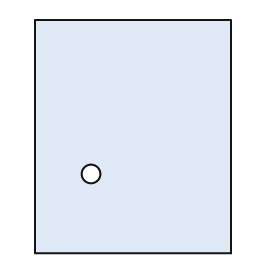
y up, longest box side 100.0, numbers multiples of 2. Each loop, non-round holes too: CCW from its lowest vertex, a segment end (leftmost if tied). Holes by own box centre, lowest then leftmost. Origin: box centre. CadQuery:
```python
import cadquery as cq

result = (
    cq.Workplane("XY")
    .moveTo(-42.0, -50.0)
    .lineTo(42.0, -50.0)
    .lineTo(42.0, 50.0)
    .lineTo(-42.0, 50.0)
    .close()
    .moveTo(-18.0, -16.0)
    .circle(4.0)
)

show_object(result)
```